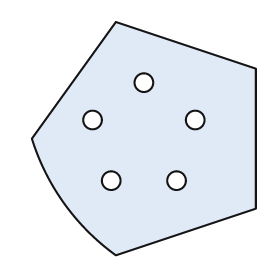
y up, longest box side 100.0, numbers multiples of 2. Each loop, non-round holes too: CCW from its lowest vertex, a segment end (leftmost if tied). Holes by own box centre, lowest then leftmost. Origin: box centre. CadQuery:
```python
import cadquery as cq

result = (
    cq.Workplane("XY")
    .moveTo(-12.0, -50.0)
    .lineTo(48.0, -30.0)
    .lineTo(48.0, 30.0)
    .lineTo(-12.0, 50.0)
    .lineTo(-48.0, 0.0)
    .threePointArc((-34.0, -28.0), (-12.0, -50.0))
    .close()
    .moveTo(-14.0, -18.0)
    .circle(4.0)
    .moveTo(14.0, -18.0)
    .circle(4.0)
    .moveTo(-22.0, 8.0)
    .circle(4.0)
    .moveTo(22.0, 8.0)
    .circle(4.0)
    .moveTo(0.0, 24.0)
    .circle(4.0)
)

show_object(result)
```